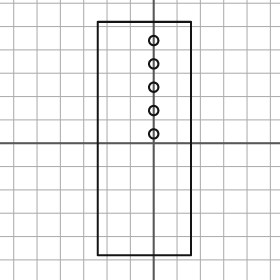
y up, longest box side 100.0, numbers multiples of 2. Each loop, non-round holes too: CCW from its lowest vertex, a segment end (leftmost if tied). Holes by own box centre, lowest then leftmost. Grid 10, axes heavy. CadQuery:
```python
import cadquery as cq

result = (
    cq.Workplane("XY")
    .moveTo(-24.0, -48.0)
    .lineTo(16.0, -48.0)
    .lineTo(16.0, 52.0)
    .lineTo(-24.0, 52.0)
    .close()
    .moveTo(0.0, 4.0)
    .circle(2.0)
    .moveTo(0.0, 14.0)
    .circle(2.0)
    .moveTo(0.0, 24.0)
    .circle(2.0)
    .moveTo(0.0, 34.0)
    .circle(2.0)
    .moveTo(0.0, 44.0)
    .circle(2.0)
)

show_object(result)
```